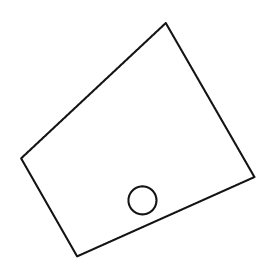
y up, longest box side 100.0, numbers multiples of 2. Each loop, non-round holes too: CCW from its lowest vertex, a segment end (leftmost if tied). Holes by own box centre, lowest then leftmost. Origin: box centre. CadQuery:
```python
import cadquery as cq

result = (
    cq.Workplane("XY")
    .moveTo(-26.0, -50.0)
    .lineTo(50.0, -16.0)
    .lineTo(12.0, 50.0)
    .lineTo(-50.0, -8.0)
    .close()
    .moveTo(2.0, -26.0)
    .circle(6.0)
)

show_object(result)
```